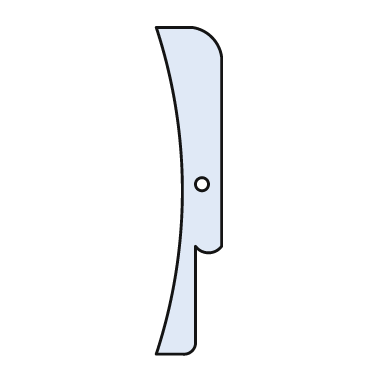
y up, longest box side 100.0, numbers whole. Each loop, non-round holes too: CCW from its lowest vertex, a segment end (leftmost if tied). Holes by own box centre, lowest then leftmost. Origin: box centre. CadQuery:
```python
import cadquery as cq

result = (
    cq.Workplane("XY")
    .moveTo(-10.0, -50.0)
    .lineTo(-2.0, -50.0)
    .threePointArc((1.0, -49.0), (2.0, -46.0))
    .lineTo(2.0, -17.0)
    .threePointArc((6.0, -19.0), (10.0, -17.0))
    .lineTo(10.0, 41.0)
    .threePointArc((7.0, 47.0), (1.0, 50.0))
    .lineTo(-10.0, 50.0)
    .threePointArc((-2.0, 0.0), (-10.0, -50.0))
    .close()
    .moveTo(4.0, 2.0)
    .circle(2.0)
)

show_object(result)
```